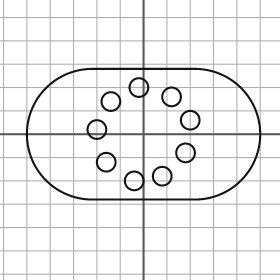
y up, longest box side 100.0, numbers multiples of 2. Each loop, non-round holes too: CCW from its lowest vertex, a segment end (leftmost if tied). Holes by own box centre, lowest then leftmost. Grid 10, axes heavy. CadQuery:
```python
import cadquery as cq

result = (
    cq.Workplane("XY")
    .moveTo(-22.0, -28.0)
    .lineTo(22.0, -28.0)
    .threePointArc((50.0, 0.0), (22.0, 28.0))
    .lineTo(-22.0, 28.0)
    .threePointArc((-50.0, 0.0), (-22.0, -28.0))
    .close()
    .moveTo(-4.0, -20.0)
    .circle(4.0)
    .moveTo(8.0, -18.0)
    .circle(4.0)
    .moveTo(-16.0, -12.0)
    .circle(4.0)
    .moveTo(18.0, -8.0)
    .circle(4.0)
    .moveTo(-20.0, 2.0)
    .circle(4.0)
    .moveTo(20.0, 6.0)
    .circle(4.0)
    .moveTo(-14.0, 14.0)
    .circle(4.0)
    .moveTo(12.0, 16.0)
    .circle(4.0)
    .moveTo(-2.0, 20.0)
    .circle(4.0)
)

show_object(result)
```